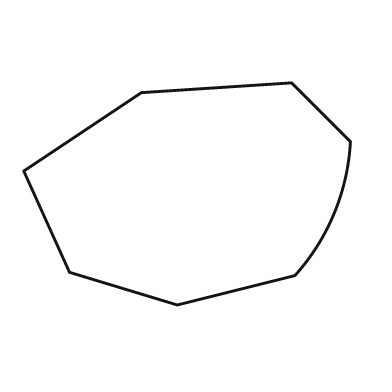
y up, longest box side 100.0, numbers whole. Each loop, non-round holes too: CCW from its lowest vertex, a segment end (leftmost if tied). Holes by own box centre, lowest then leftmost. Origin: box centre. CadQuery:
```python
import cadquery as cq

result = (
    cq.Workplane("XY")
    .moveTo(-3.0, -34.0)
    .lineTo(33.0, -25.0)
    .threePointArc((45.0, -6.0), (50.0, 16.0))
    .lineTo(32.0, 34.0)
    .lineTo(-14.0, 31.0)
    .lineTo(-50.0, 7.0)
    .lineTo(-36.0, -24.0)
    .close()
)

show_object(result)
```